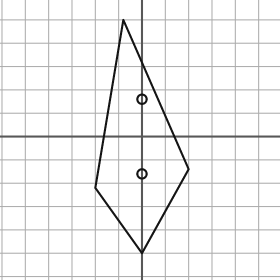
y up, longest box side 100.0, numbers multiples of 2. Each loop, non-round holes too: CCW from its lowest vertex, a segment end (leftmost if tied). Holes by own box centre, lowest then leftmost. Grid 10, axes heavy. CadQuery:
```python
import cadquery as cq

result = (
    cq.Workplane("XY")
    .moveTo(0.0, -50.0)
    .lineTo(20.0, -14.0)
    .lineTo(-8.0, 50.0)
    .lineTo(-20.0, -22.0)
    .close()
    .moveTo(0.0, -16.0)
    .circle(2.0)
    .moveTo(0.0, 16.0)
    .circle(2.0)
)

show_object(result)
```